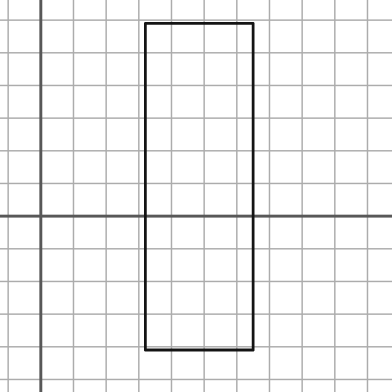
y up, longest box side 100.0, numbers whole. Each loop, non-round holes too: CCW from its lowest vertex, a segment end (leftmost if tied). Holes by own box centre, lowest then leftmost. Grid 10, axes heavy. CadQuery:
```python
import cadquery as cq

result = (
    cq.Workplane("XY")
    .moveTo(32.0, -41.0)
    .lineTo(65.0, -41.0)
    .lineTo(65.0, 59.0)
    .lineTo(32.0, 59.0)
    .close()
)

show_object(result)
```